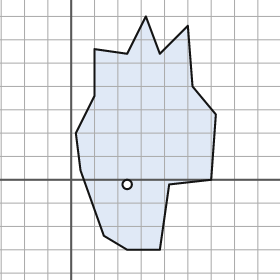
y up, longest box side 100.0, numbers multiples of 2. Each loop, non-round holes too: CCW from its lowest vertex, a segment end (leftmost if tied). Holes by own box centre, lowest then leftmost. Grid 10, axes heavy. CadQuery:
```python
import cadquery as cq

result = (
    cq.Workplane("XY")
    .moveTo(24.0, -30.0)
    .lineTo(38.0, -30.0)
    .lineTo(42.0, -2.0)
    .lineTo(60.0, 0.0)
    .lineTo(62.0, 28.0)
    .lineTo(52.0, 40.0)
    .lineTo(50.0, 66.0)
    .lineTo(38.0, 54.0)
    .lineTo(32.0, 70.0)
    .lineTo(24.0, 54.0)
    .lineTo(10.0, 56.0)
    .lineTo(10.0, 36.0)
    .lineTo(2.0, 20.0)
    .lineTo(4.0, 4.0)
    .lineTo(14.0, -24.0)
    .close()
    .moveTo(24.0, -2.0)
    .circle(2.0)
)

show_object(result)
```